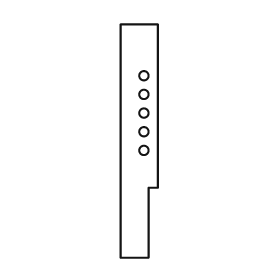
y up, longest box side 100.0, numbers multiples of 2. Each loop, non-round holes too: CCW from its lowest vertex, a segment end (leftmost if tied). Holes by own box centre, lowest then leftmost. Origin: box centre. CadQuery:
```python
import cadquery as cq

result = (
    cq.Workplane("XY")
    .moveTo(-8.0, -50.0)
    .lineTo(4.0, -50.0)
    .lineTo(4.0, -20.0)
    .lineTo(8.0, -20.0)
    .lineTo(8.0, 50.0)
    .lineTo(-8.0, 50.0)
    .close()
    .moveTo(2.0, -4.0)
    .circle(2.0)
    .moveTo(2.0, 4.0)
    .circle(2.0)
    .moveTo(2.0, 12.0)
    .circle(2.0)
    .moveTo(2.0, 20.0)
    .circle(2.0)
    .moveTo(2.0, 28.0)
    .circle(2.0)
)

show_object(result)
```